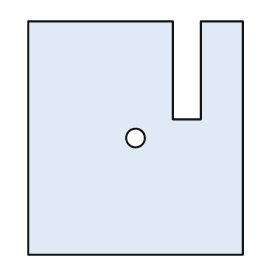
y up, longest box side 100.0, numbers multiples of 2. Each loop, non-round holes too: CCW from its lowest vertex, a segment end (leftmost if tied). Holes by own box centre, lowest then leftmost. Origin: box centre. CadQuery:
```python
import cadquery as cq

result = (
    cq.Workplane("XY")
    .moveTo(-46.0, -50.0)
    .lineTo(46.0, -50.0)
    .lineTo(46.0, 50.0)
    .lineTo(28.0, 50.0)
    .lineTo(28.0, 8.0)
    .lineTo(16.0, 8.0)
    .lineTo(16.0, 50.0)
    .lineTo(-46.0, 50.0)
    .close()
    .moveTo(0.0, 0.0)
    .circle(4.0)
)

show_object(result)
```